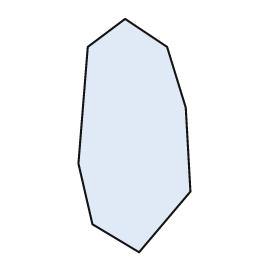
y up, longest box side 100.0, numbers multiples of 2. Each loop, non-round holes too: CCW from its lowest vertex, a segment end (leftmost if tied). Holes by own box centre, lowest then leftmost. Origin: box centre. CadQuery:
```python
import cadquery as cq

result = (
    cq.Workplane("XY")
    .moveTo(2.0, -50.0)
    .lineTo(24.0, -24.0)
    .lineTo(22.0, 12.0)
    .lineTo(14.0, 38.0)
    .lineTo(-4.0, 50.0)
    .lineTo(-20.0, 38.0)
    .lineTo(-24.0, -12.0)
    .lineTo(-18.0, -38.0)
    .close()
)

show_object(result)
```